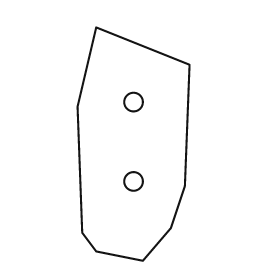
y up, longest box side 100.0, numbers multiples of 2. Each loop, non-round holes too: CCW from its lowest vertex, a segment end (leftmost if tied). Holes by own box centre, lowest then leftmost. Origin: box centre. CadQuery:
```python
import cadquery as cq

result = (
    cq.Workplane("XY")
    .moveTo(4.0, -50.0)
    .lineTo(16.0, -36.0)
    .lineTo(22.0, -18.0)
    .lineTo(24.0, 34.0)
    .lineTo(-16.0, 50.0)
    .lineTo(-24.0, 16.0)
    .lineTo(-22.0, -38.0)
    .lineTo(-16.0, -46.0)
    .close()
    .moveTo(0.0, -16.0)
    .circle(4.0)
    .moveTo(0.0, 18.0)
    .circle(4.0)
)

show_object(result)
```